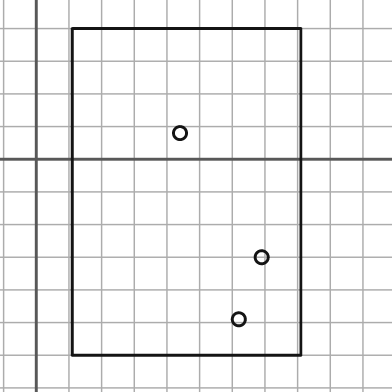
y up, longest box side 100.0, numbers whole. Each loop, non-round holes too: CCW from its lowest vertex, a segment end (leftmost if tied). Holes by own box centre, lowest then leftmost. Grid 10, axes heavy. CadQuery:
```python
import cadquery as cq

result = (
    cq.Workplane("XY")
    .moveTo(11.0, -60.0)
    .lineTo(81.0, -60.0)
    .lineTo(81.0, 40.0)
    .lineTo(11.0, 40.0)
    .close()
    .moveTo(62.0, -49.0)
    .circle(2.0)
    .moveTo(69.0, -30.0)
    .circle(2.0)
    .moveTo(44.0, 8.0)
    .circle(2.0)
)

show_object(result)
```